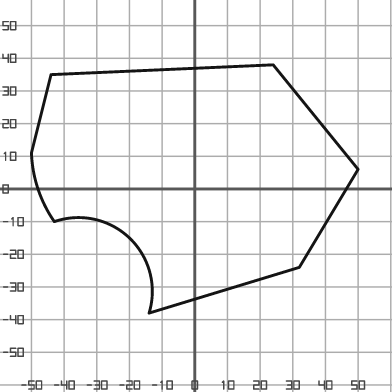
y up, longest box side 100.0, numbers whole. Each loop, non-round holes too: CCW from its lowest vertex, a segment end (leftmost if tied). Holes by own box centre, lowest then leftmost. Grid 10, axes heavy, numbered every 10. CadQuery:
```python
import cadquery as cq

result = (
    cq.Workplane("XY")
    .moveTo(-14.0, -38.0)
    .lineTo(32.0, -24.0)
    .lineTo(50.0, 6.0)
    .lineTo(24.0, 38.0)
    .lineTo(-44.0, 35.0)
    .lineTo(-50.0, 11.0)
    .threePointArc((-48.0, 0.0), (-43.0, -10.0))
    .threePointArc((-20.0, -15.0), (-14.0, -38.0))
    .close()
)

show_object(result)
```